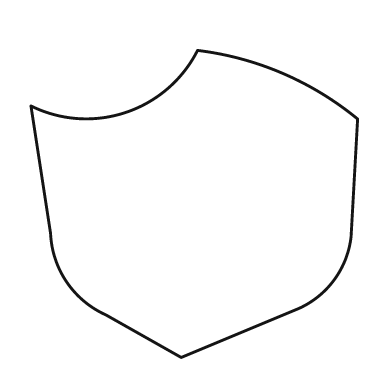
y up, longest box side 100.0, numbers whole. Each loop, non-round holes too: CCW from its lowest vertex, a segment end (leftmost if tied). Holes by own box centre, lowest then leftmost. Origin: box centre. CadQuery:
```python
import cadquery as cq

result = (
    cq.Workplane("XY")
    .moveTo(-4.0, -47.0)
    .lineTo(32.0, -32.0)
    .threePointArc((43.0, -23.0), (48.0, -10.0))
    .lineTo(50.0, 26.0)
    .threePointArc((27.0, 40.0), (1.0, 47.0))
    .threePointArc((-21.0, 28.0), (-50.0, 30.0))
    .lineTo(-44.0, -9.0)
    .threePointArc((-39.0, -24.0), (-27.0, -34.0))
    .close()
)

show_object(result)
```